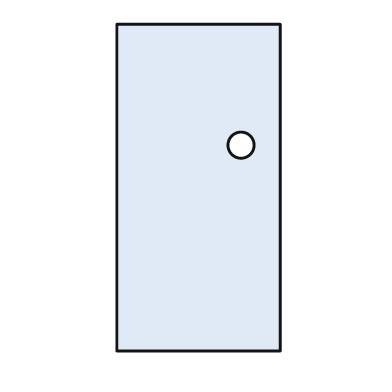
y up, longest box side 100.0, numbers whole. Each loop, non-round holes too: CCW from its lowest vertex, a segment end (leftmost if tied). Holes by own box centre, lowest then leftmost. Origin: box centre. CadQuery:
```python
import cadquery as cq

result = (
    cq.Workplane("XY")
    .moveTo(-25.0, -50.0)
    .lineTo(25.0, -50.0)
    .lineTo(25.0, 50.0)
    .lineTo(-25.0, 50.0)
    .close()
    .moveTo(13.0, 13.0)
    .circle(4.0)
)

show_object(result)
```